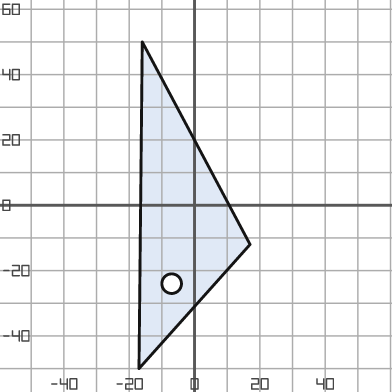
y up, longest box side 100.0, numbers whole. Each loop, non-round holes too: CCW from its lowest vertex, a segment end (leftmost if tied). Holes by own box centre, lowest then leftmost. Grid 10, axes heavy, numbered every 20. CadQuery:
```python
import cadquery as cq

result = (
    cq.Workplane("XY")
    .moveTo(-17.0, -50.0)
    .lineTo(17.0, -12.0)
    .lineTo(-16.0, 50.0)
    .close()
    .moveTo(-7.0, -24.0)
    .circle(3.0)
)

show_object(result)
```